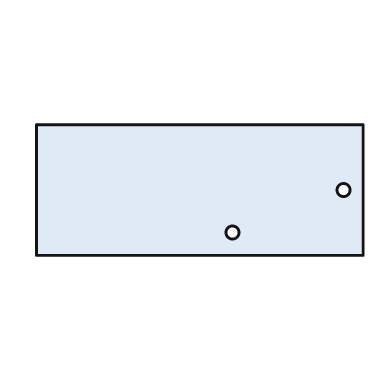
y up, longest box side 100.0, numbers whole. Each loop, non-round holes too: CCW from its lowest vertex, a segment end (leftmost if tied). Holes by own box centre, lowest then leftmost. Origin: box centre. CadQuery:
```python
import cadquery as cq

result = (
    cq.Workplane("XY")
    .moveTo(-50.0, -20.0)
    .lineTo(50.0, -20.0)
    .lineTo(50.0, 20.0)
    .lineTo(-50.0, 20.0)
    .close()
    .moveTo(10.0, -13.0)
    .circle(2.0)
    .moveTo(44.0, 0.0)
    .circle(2.0)
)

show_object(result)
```